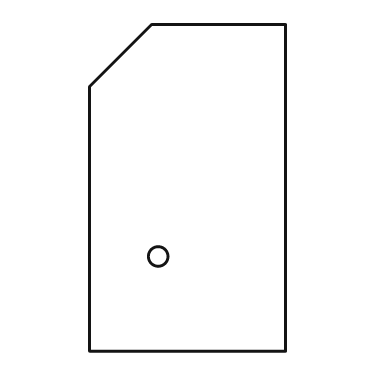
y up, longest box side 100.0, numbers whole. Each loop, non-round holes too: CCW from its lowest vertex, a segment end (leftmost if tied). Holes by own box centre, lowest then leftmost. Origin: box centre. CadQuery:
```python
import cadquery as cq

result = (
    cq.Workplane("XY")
    .moveTo(-30.0, -50.0)
    .lineTo(30.0, -50.0)
    .lineTo(30.0, 50.0)
    .lineTo(-11.0, 50.0)
    .lineTo(-30.0, 31.0)
    .close()
    .moveTo(-9.0, -21.0)
    .circle(3.0)
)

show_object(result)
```